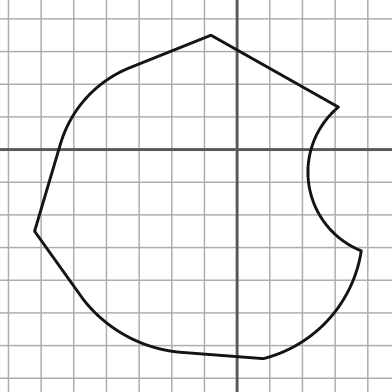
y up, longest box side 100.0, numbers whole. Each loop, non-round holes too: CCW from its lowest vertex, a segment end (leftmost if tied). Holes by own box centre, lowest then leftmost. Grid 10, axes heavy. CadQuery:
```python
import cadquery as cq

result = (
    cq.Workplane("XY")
    .moveTo(8.0, -64.0)
    .threePointArc((28.0, -52.0), (38.0, -31.0))
    .threePointArc((22.0, -11.0), (31.0, 13.0))
    .lineTo(-8.0, 35.0)
    .lineTo(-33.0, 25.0)
    .threePointArc((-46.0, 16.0), (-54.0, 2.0))
    .lineTo(-62.0, -25.0)
    .lineTo(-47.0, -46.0)
    .threePointArc((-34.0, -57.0), (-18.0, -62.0))
    .close()
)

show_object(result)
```